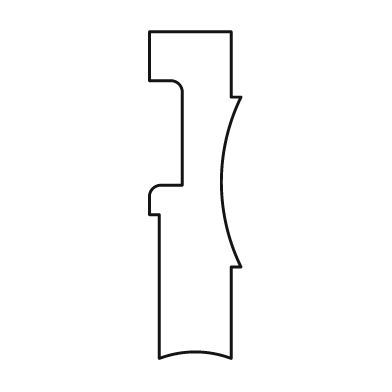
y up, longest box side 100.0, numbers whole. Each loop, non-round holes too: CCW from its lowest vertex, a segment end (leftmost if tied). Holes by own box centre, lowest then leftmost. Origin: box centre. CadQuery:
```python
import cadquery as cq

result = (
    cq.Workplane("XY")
    .moveTo(-11.0, -50.0)
    .threePointArc((0.0, -48.0), (11.0, -50.0))
    .lineTo(11.0, -22.0)
    .lineTo(14.0, -22.0)
    .threePointArc((8.0, 4.0), (14.0, 30.0))
    .lineTo(11.0, 30.0)
    .lineTo(11.0, 50.0)
    .lineTo(-14.0, 50.0)
    .lineTo(-14.0, 35.0)
    .lineTo(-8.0, 35.0)
    .threePointArc((-5.0, 34.0), (-4.0, 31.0))
    .lineTo(-4.0, 3.0)
    .lineTo(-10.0, 3.0)
    .threePointArc((-13.0, 2.0), (-14.0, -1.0))
    .lineTo(-14.0, -6.0)
    .lineTo(-11.0, -6.0)
    .close()
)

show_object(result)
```